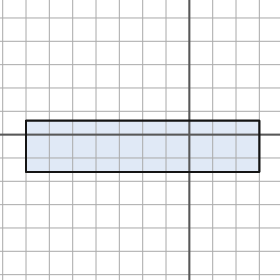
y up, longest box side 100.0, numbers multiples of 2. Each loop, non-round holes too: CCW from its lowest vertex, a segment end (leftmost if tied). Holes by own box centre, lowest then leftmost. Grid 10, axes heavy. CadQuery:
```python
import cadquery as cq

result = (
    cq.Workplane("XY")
    .moveTo(-70.0, -16.0)
    .lineTo(30.0, -16.0)
    .lineTo(30.0, 6.0)
    .lineTo(-70.0, 6.0)
    .close()
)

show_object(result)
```